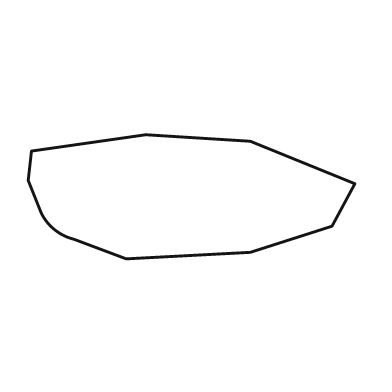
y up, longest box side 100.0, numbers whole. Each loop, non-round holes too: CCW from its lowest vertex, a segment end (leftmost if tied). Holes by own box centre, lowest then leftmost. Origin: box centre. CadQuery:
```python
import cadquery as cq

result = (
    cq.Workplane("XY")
    .moveTo(-20.0, -19.0)
    .lineTo(18.0, -17.0)
    .lineTo(43.0, -9.0)
    .lineTo(50.0, 4.0)
    .lineTo(18.0, 17.0)
    .lineTo(-14.0, 19.0)
    .lineTo(-49.0, 14.0)
    .lineTo(-50.0, 5.0)
    .lineTo(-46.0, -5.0)
    .threePointArc((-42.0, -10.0), (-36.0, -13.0))
    .close()
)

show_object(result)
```